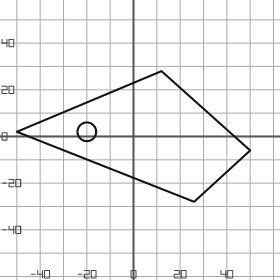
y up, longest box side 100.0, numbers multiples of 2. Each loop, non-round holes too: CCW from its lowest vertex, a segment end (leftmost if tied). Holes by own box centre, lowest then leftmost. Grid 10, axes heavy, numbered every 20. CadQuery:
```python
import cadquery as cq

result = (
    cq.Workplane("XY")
    .moveTo(26.0, -28.0)
    .lineTo(50.0, -6.0)
    .lineTo(12.0, 28.0)
    .lineTo(-50.0, 2.0)
    .close()
    .moveTo(-20.0, 2.0)
    .circle(4.0)
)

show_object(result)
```